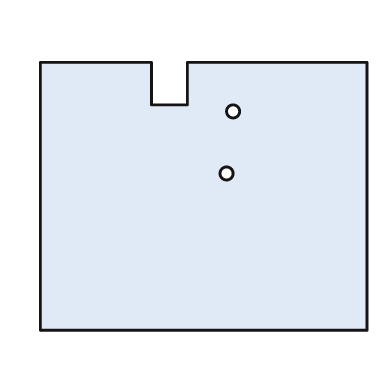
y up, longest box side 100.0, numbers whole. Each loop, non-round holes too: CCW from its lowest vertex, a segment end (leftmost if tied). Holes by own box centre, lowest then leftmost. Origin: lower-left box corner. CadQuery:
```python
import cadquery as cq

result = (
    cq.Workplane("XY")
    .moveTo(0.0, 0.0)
    .lineTo(100.0, 0.0)
    .lineTo(100.0, 82.0)
    .lineTo(45.0, 82.0)
    .lineTo(45.0, 69.0)
    .lineTo(34.0, 69.0)
    .lineTo(34.0, 82.0)
    .lineTo(0.0, 82.0)
    .close()
    .moveTo(57.0, 48.0)
    .circle(2.0)
    .moveTo(59.0, 67.0)
    .circle(2.0)
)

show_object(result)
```